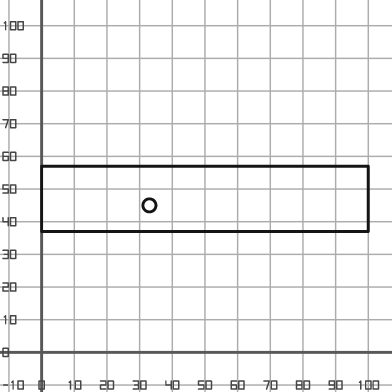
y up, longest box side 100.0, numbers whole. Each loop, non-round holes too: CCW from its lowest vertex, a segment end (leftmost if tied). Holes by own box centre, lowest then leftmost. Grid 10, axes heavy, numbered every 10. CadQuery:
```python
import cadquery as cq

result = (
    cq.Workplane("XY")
    .moveTo(0.0, 37.0)
    .lineTo(100.0, 37.0)
    .lineTo(100.0, 57.0)
    .lineTo(0.0, 57.0)
    .close()
    .moveTo(33.0, 45.0)
    .circle(2.0)
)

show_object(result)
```